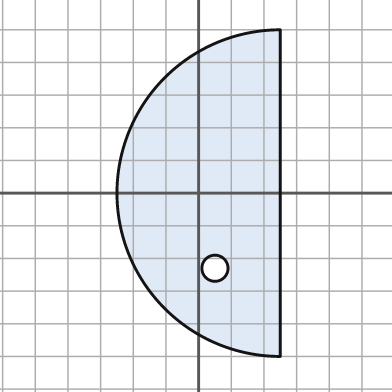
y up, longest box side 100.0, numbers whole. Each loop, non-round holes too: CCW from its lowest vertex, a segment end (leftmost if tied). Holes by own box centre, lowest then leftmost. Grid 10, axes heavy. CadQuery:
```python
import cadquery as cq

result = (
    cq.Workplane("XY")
    .moveTo(25.0, -50.0)
    .lineTo(25.0, 50.0)
    .threePointArc((-25.0, 0.0), (25.0, -50.0))
    .close()
    .moveTo(5.0, -23.0)
    .circle(4.0)
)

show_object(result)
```